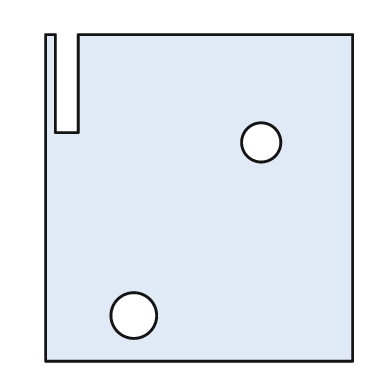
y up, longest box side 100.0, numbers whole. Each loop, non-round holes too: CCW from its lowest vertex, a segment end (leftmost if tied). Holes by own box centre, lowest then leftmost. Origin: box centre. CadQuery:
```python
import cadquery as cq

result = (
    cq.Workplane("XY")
    .moveTo(-47.0, -50.0)
    .lineTo(47.0, -50.0)
    .lineTo(47.0, 50.0)
    .lineTo(-37.0, 50.0)
    .lineTo(-37.0, 20.0)
    .lineTo(-44.0, 20.0)
    .lineTo(-44.0, 50.0)
    .lineTo(-47.0, 50.0)
    .close()
    .moveTo(-20.0, -36.0)
    .circle(7.0)
    .moveTo(19.0, 17.0)
    .circle(6.0)
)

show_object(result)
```